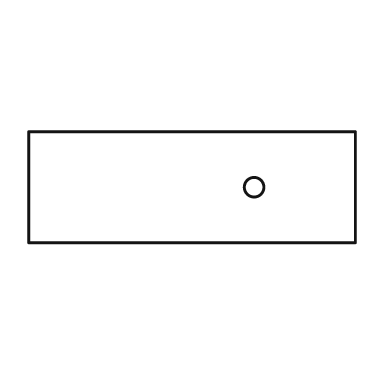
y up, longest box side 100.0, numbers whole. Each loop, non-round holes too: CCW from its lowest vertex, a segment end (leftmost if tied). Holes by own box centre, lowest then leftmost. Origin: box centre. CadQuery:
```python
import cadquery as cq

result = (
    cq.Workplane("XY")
    .moveTo(-50.0, -17.0)
    .lineTo(50.0, -17.0)
    .lineTo(50.0, 17.0)
    .lineTo(-50.0, 17.0)
    .close()
    .moveTo(19.0, 0.0)
    .circle(3.0)
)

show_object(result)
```